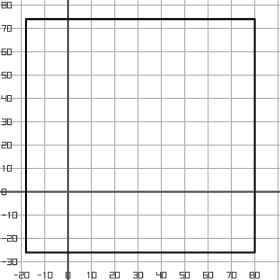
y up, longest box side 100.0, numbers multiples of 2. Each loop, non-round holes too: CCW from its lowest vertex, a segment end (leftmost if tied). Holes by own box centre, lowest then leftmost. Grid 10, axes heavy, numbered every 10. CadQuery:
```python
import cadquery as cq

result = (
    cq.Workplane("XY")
    .moveTo(-18.0, -26.0)
    .lineTo(80.0, -26.0)
    .lineTo(80.0, 74.0)
    .lineTo(-18.0, 74.0)
    .close()
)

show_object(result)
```